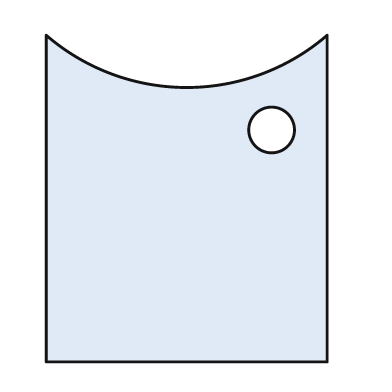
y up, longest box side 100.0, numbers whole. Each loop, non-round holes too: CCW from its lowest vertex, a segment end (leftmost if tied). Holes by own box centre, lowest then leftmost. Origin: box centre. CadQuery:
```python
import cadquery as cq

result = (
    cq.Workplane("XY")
    .moveTo(-43.0, -50.0)
    .lineTo(43.0, -50.0)
    .lineTo(43.0, 50.0)
    .threePointArc((0.0, 34.0), (-43.0, 50.0))
    .close()
    .moveTo(26.0, 21.0)
    .circle(7.0)
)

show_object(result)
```